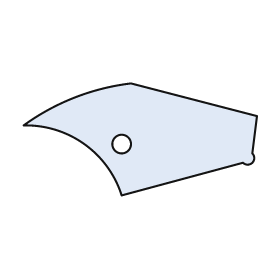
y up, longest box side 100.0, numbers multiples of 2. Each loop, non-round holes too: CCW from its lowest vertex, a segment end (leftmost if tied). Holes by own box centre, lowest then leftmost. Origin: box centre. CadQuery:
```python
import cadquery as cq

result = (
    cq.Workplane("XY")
    .moveTo(-8.0, -24.0)
    .lineTo(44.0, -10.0)
    .threePointArc((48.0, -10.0), (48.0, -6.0))
    .lineTo(50.0, 10.0)
    .lineTo(-4.0, 24.0)
    .threePointArc((-28.0, 18.0), (-50.0, 6.0))
    .threePointArc((-24.0, -2.0), (-8.0, -24.0))
    .close()
    .moveTo(-8.0, -2.0)
    .circle(4.0)
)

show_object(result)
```